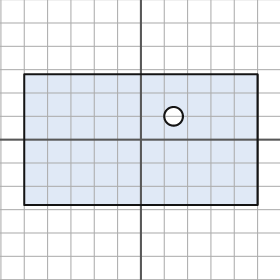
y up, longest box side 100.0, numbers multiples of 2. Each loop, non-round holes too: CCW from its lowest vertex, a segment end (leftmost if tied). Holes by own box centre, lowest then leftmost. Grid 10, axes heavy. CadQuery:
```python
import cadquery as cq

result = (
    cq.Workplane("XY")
    .moveTo(-50.0, -28.0)
    .lineTo(50.0, -28.0)
    .lineTo(50.0, 28.0)
    .lineTo(-50.0, 28.0)
    .close()
    .moveTo(14.0, 10.0)
    .circle(4.0)
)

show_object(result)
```